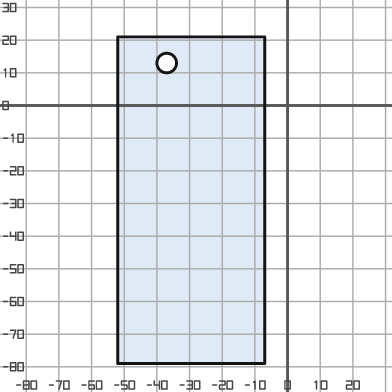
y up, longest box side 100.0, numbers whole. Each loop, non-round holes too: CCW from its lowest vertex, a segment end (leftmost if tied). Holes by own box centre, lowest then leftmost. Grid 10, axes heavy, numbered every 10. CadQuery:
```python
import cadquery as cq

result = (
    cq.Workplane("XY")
    .moveTo(-52.0, -79.0)
    .lineTo(-7.0, -79.0)
    .lineTo(-7.0, 21.0)
    .lineTo(-52.0, 21.0)
    .close()
    .moveTo(-37.0, 13.0)
    .circle(3.0)
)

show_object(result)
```